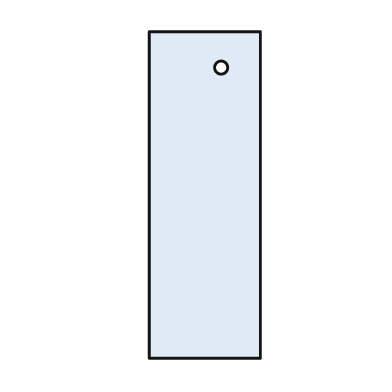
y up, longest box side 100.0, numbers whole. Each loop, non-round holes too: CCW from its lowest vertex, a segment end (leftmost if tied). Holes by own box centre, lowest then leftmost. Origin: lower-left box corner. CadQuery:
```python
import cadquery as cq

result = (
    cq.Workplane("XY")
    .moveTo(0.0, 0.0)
    .lineTo(34.0, 0.0)
    .lineTo(34.0, 100.0)
    .lineTo(0.0, 100.0)
    .close()
    .moveTo(22.0, 89.0)
    .circle(2.0)
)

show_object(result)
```